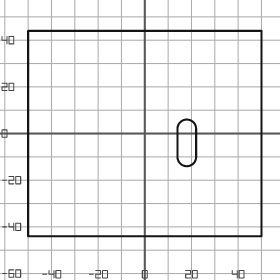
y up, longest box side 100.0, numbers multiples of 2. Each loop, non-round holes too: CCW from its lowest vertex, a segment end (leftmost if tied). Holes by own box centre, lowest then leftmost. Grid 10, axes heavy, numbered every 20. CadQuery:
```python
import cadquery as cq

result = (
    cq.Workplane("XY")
    .moveTo(-50.0, -44.0)
    .lineTo(50.0, -44.0)
    .lineTo(50.0, 44.0)
    .lineTo(-50.0, 44.0)
    .close()
    .moveTo(14.0, -10.0)
    .threePointArc((18.0, -14.0), (22.0, -10.0))
    .lineTo(22.0, 2.0)
    .threePointArc((18.0, 6.0), (14.0, 2.0))
    .close()
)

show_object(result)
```